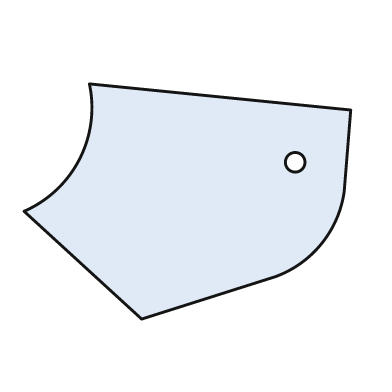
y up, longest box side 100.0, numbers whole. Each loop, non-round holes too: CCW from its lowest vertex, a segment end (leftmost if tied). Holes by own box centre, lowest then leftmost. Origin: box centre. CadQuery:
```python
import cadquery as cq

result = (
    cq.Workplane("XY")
    .moveTo(-14.0, -36.0)
    .lineTo(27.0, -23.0)
    .threePointArc((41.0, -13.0), (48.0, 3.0))
    .lineTo(50.0, 28.0)
    .lineTo(-30.0, 36.0)
    .threePointArc((-33.0, 13.0), (-50.0, -3.0))
    .close()
    .moveTo(33.0, 12.0)
    .circle(3.0)
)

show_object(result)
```